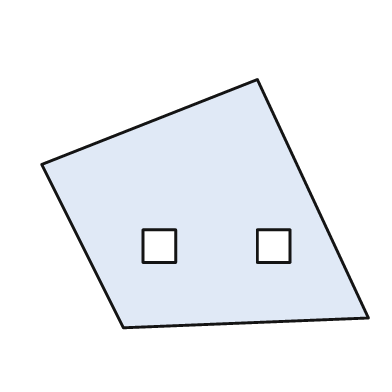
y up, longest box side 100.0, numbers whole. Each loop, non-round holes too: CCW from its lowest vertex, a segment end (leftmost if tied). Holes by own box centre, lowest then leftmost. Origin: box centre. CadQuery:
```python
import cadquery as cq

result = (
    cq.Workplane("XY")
    .moveTo(-25.0, -38.0)
    .lineTo(50.0, -35.0)
    .lineTo(16.0, 38.0)
    .lineTo(-50.0, 12.0)
    .close()
    .moveTo(-19.0, -18.0)
    .lineTo(-9.0, -18.0)
    .lineTo(-9.0, -8.0)
    .lineTo(-19.0, -8.0)
    .close()
    .moveTo(16.0, -18.0)
    .lineTo(26.0, -18.0)
    .lineTo(26.0, -8.0)
    .lineTo(16.0, -8.0)
    .close()
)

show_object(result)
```